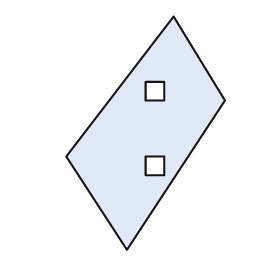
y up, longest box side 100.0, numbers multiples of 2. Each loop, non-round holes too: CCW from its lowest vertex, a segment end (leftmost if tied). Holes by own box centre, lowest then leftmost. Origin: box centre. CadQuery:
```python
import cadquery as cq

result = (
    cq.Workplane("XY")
    .moveTo(-8.0, -50.0)
    .lineTo(34.0, 14.0)
    .lineTo(12.0, 50.0)
    .lineTo(-34.0, -10.0)
    .close()
    .moveTo(0.0, -18.0)
    .lineTo(8.0, -18.0)
    .lineTo(8.0, -10.0)
    .lineTo(0.0, -10.0)
    .close()
    .moveTo(0.0, 14.0)
    .lineTo(8.0, 14.0)
    .lineTo(8.0, 22.0)
    .lineTo(0.0, 22.0)
    .close()
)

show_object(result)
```